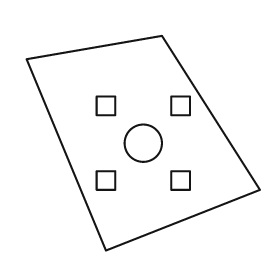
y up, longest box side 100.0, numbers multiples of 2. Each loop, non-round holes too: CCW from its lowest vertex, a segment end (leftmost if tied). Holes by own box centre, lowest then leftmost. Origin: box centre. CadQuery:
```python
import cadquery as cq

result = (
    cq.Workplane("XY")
    .moveTo(-16.0, -46.0)
    .lineTo(50.0, -20.0)
    .lineTo(8.0, 46.0)
    .lineTo(-50.0, 36.0)
    .close()
    .moveTo(-20.0, -20.0)
    .lineTo(-12.0, -20.0)
    .lineTo(-12.0, -12.0)
    .lineTo(-20.0, -12.0)
    .close()
    .moveTo(12.0, -20.0)
    .lineTo(20.0, -20.0)
    .lineTo(20.0, -12.0)
    .lineTo(12.0, -12.0)
    .close()
    .moveTo(0.0, 0.0)
    .circle(8.0)
    .moveTo(-20.0, 12.0)
    .lineTo(-12.0, 12.0)
    .lineTo(-12.0, 20.0)
    .lineTo(-20.0, 20.0)
    .close()
    .moveTo(12.0, 12.0)
    .lineTo(20.0, 12.0)
    .lineTo(20.0, 20.0)
    .lineTo(12.0, 20.0)
    .close()
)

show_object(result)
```